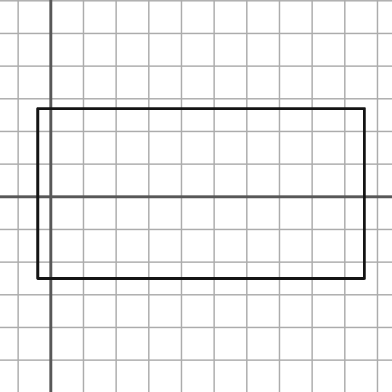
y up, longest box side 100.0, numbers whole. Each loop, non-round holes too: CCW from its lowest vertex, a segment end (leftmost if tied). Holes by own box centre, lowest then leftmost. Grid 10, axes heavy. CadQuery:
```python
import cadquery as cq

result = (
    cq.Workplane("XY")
    .moveTo(-4.0, -25.0)
    .lineTo(96.0, -25.0)
    .lineTo(96.0, 27.0)
    .lineTo(-4.0, 27.0)
    .close()
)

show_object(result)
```